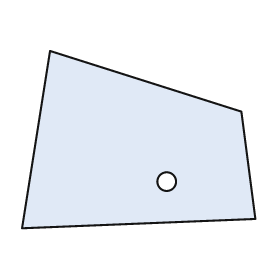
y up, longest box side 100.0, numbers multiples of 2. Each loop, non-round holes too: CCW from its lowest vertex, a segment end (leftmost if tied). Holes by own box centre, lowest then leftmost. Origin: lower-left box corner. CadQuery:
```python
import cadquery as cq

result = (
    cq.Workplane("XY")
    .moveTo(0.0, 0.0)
    .lineTo(100.0, 4.0)
    .lineTo(94.0, 50.0)
    .lineTo(12.0, 76.0)
    .close()
    .moveTo(62.0, 20.0)
    .circle(4.0)
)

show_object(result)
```